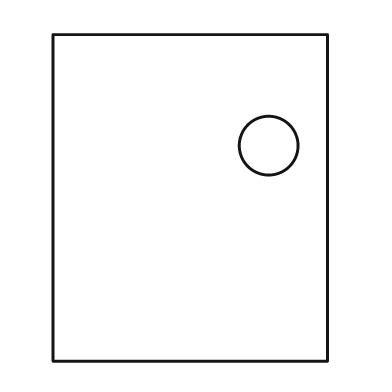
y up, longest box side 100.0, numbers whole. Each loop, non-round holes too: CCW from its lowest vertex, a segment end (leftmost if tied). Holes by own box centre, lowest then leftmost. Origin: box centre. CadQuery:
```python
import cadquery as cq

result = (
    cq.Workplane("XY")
    .moveTo(-42.0, -50.0)
    .lineTo(42.0, -50.0)
    .lineTo(42.0, 50.0)
    .lineTo(-42.0, 50.0)
    .close()
    .moveTo(24.0, 16.0)
    .circle(9.0)
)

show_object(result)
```